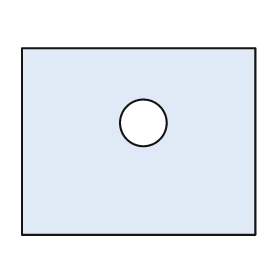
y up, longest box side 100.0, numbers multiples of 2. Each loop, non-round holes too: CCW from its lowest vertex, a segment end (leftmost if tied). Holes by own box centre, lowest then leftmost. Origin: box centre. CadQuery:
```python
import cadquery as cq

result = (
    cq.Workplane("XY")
    .moveTo(-50.0, -40.0)
    .lineTo(50.0, -40.0)
    .lineTo(50.0, 40.0)
    .lineTo(-50.0, 40.0)
    .close()
    .moveTo(2.0, 8.0)
    .circle(10.0)
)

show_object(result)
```